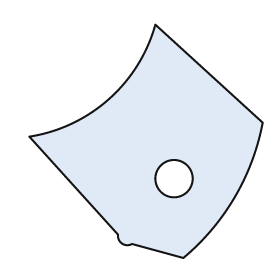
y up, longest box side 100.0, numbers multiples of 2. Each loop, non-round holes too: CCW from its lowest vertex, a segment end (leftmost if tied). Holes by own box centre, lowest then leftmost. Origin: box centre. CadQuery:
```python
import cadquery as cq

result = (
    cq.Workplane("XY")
    .moveTo(16.0, -50.0)
    .threePointArc((38.0, -24.0), (50.0, 8.0))
    .lineTo(4.0, 50.0)
    .threePointArc((-16.0, 18.0), (-50.0, 2.0))
    .lineTo(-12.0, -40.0)
    .threePointArc((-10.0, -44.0), (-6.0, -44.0))
    .close()
    .moveTo(12.0, -16.0)
    .circle(8.0)
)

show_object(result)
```